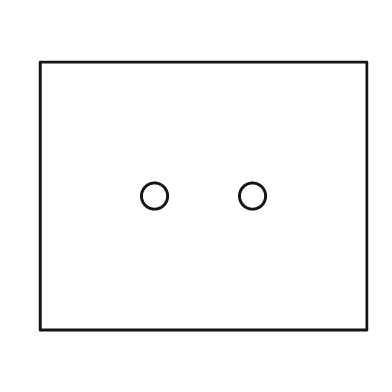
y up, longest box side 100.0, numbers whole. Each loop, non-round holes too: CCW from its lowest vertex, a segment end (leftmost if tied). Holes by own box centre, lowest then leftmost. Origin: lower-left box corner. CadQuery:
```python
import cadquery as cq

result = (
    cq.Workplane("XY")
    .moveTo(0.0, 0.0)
    .lineTo(100.0, 0.0)
    .lineTo(100.0, 82.0)
    .lineTo(0.0, 82.0)
    .close()
    .moveTo(35.0, 41.0)
    .circle(4.0)
    .moveTo(65.0, 41.0)
    .circle(4.0)
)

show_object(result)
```